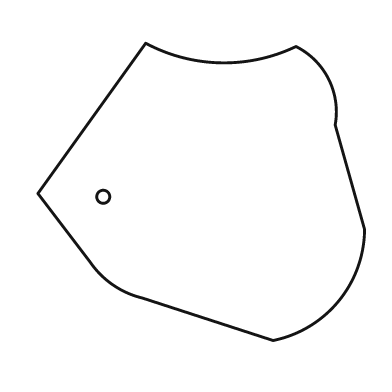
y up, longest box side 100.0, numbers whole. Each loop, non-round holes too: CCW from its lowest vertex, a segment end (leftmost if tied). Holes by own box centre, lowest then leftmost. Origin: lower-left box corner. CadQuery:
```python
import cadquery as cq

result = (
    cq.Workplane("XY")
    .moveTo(72.0, 0.0)
    .threePointArc((92.0, 12.0), (100.0, 34.0))
    .lineTo(91.0, 66.0)
    .threePointArc((89.0, 80.0), (79.0, 90.0))
    .threePointArc((56.0, 85.0), (33.0, 91.0))
    .lineTo(0.0, 45.0)
    .lineTo(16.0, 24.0)
    .threePointArc((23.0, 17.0), (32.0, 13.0))
    .close()
    .moveTo(20.0, 44.0)
    .circle(2.0)
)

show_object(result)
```